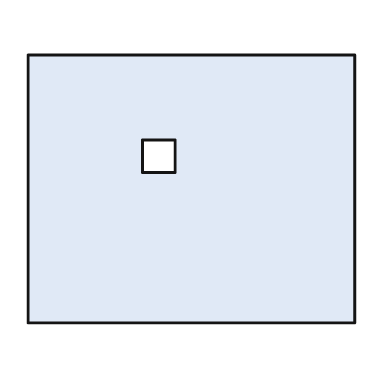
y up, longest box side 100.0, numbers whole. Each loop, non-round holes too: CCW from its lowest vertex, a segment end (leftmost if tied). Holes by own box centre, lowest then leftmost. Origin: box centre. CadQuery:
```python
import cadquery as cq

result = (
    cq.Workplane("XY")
    .moveTo(-50.0, -41.0)
    .lineTo(50.0, -41.0)
    .lineTo(50.0, 41.0)
    .lineTo(-50.0, 41.0)
    .close()
    .moveTo(-15.0, 5.0)
    .lineTo(-5.0, 5.0)
    .lineTo(-5.0, 15.0)
    .lineTo(-15.0, 15.0)
    .close()
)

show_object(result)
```